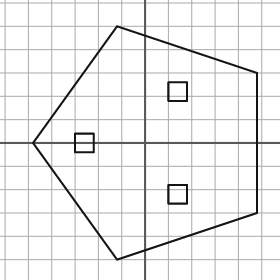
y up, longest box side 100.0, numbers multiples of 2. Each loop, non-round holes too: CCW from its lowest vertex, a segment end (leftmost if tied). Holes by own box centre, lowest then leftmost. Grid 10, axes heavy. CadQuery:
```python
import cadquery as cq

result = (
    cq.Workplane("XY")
    .moveTo(-12.0, -50.0)
    .lineTo(48.0, -30.0)
    .lineTo(48.0, 30.0)
    .lineTo(-12.0, 50.0)
    .lineTo(-48.0, 0.0)
    .close()
    .moveTo(10.0, -26.0)
    .lineTo(18.0, -26.0)
    .lineTo(18.0, -18.0)
    .lineTo(10.0, -18.0)
    .close()
    .moveTo(-30.0, -4.0)
    .lineTo(-22.0, -4.0)
    .lineTo(-22.0, 4.0)
    .lineTo(-30.0, 4.0)
    .close()
    .moveTo(10.0, 18.0)
    .lineTo(18.0, 18.0)
    .lineTo(18.0, 26.0)
    .lineTo(10.0, 26.0)
    .close()
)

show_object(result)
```